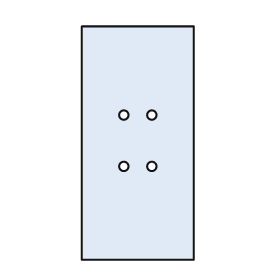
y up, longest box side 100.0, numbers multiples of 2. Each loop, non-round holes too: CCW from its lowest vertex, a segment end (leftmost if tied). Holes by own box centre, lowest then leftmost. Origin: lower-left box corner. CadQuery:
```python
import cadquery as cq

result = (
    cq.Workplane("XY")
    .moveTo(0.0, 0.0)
    .lineTo(48.0, 0.0)
    .lineTo(48.0, 100.0)
    .lineTo(0.0, 100.0)
    .close()
    .moveTo(18.0, 40.0)
    .circle(2.0)
    .moveTo(30.0, 40.0)
    .circle(2.0)
    .moveTo(18.0, 62.0)
    .circle(2.0)
    .moveTo(30.0, 62.0)
    .circle(2.0)
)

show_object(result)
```